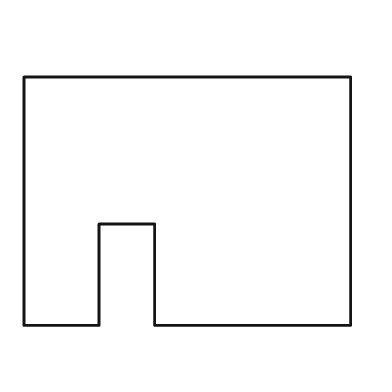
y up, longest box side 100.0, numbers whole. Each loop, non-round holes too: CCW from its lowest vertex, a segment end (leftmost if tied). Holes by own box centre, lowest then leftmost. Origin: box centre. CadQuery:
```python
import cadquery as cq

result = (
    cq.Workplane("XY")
    .moveTo(-50.0, -38.0)
    .lineTo(-27.0, -38.0)
    .lineTo(-27.0, -7.0)
    .lineTo(-10.0, -7.0)
    .lineTo(-10.0, -38.0)
    .lineTo(50.0, -38.0)
    .lineTo(50.0, 38.0)
    .lineTo(-50.0, 38.0)
    .close()
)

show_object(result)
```